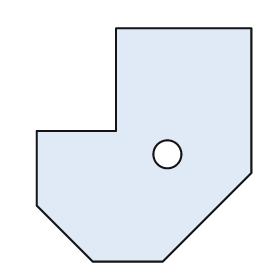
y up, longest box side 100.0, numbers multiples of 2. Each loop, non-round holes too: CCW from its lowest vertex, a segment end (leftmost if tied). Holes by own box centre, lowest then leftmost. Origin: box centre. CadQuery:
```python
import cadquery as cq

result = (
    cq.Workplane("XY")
    .moveTo(-22.0, -50.0)
    .lineTo(8.0, -50.0)
    .lineTo(46.0, -12.0)
    .lineTo(46.0, 50.0)
    .lineTo(-12.0, 50.0)
    .lineTo(-12.0, 6.0)
    .lineTo(-46.0, 6.0)
    .lineTo(-46.0, -26.0)
    .close()
    .moveTo(10.0, -4.0)
    .circle(6.0)
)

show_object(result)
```